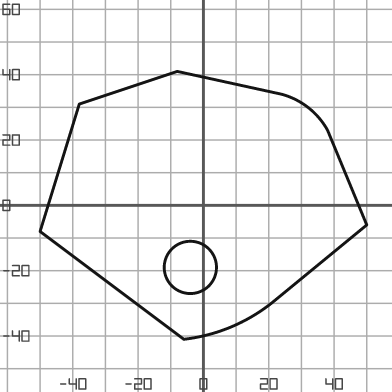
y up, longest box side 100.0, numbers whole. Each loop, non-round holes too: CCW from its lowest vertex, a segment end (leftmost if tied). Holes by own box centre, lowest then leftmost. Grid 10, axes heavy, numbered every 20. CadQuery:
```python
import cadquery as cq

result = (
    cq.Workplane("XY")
    .moveTo(-6.0, -41.0)
    .threePointArc((9.0, -37.0), (22.0, -29.0))
    .lineTo(50.0, -6.0)
    .lineTo(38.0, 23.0)
    .threePointArc((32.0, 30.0), (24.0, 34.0))
    .lineTo(-8.0, 41.0)
    .lineTo(-38.0, 31.0)
    .lineTo(-50.0, -8.0)
    .close()
    .moveTo(-4.0, -19.0)
    .circle(8.0)
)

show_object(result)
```